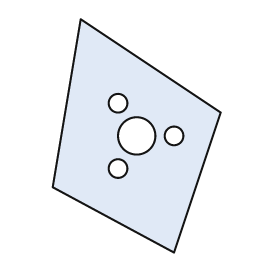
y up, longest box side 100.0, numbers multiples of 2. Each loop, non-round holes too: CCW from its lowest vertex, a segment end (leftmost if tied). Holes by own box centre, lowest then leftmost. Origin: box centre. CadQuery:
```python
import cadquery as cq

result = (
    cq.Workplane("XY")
    .moveTo(16.0, -50.0)
    .lineTo(36.0, 10.0)
    .lineTo(-24.0, 50.0)
    .lineTo(-36.0, -22.0)
    .close()
    .moveTo(-8.0, -14.0)
    .circle(4.0)
    .moveTo(0.0, 0.0)
    .circle(8.0)
    .moveTo(16.0, 0.0)
    .circle(4.0)
    .moveTo(-8.0, 14.0)
    .circle(4.0)
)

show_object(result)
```